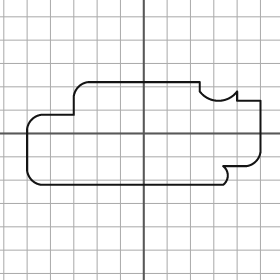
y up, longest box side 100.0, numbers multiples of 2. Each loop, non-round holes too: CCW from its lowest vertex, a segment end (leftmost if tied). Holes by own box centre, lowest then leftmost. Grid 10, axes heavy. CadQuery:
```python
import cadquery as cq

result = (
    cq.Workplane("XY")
    .moveTo(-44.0, -22.0)
    .lineTo(34.0, -22.0)
    .threePointArc((36.0, -18.0), (34.0, -14.0))
    .lineTo(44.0, -14.0)
    .threePointArc((48.0, -12.0), (50.0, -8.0))
    .lineTo(50.0, 14.0)
    .lineTo(40.0, 14.0)
    .lineTo(40.0, 18.0)
    .threePointArc((32.0, 14.0), (24.0, 18.0))
    .lineTo(24.0, 22.0)
    .lineTo(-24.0, 22.0)
    .threePointArc((-28.0, 20.0), (-30.0, 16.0))
    .lineTo(-30.0, 8.0)
    .lineTo(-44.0, 8.0)
    .threePointArc((-48.0, 6.0), (-50.0, 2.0))
    .lineTo(-50.0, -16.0)
    .threePointArc((-48.0, -20.0), (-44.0, -22.0))
    .close()
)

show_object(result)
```